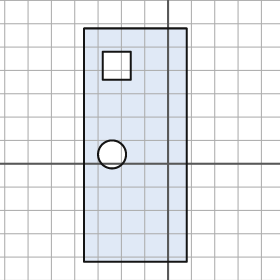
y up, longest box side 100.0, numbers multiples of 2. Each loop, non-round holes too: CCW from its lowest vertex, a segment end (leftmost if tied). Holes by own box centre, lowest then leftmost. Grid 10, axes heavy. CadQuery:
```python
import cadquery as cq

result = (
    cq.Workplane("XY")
    .moveTo(-36.0, -42.0)
    .lineTo(8.0, -42.0)
    .lineTo(8.0, 58.0)
    .lineTo(-36.0, 58.0)
    .close()
    .moveTo(-24.0, 4.0)
    .circle(6.0)
    .moveTo(-28.0, 36.0)
    .lineTo(-16.0, 36.0)
    .lineTo(-16.0, 48.0)
    .lineTo(-28.0, 48.0)
    .close()
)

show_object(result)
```